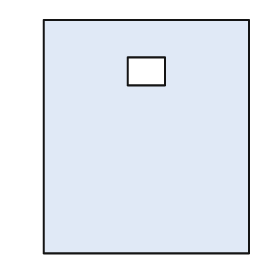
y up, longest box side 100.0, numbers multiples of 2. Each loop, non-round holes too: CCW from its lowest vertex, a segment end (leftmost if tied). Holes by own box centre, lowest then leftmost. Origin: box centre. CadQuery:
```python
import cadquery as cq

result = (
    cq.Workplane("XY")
    .moveTo(-44.0, -50.0)
    .lineTo(44.0, -50.0)
    .lineTo(44.0, 50.0)
    .lineTo(-44.0, 50.0)
    .close()
    .moveTo(-8.0, 22.0)
    .lineTo(8.0, 22.0)
    .lineTo(8.0, 34.0)
    .lineTo(-8.0, 34.0)
    .close()
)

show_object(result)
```